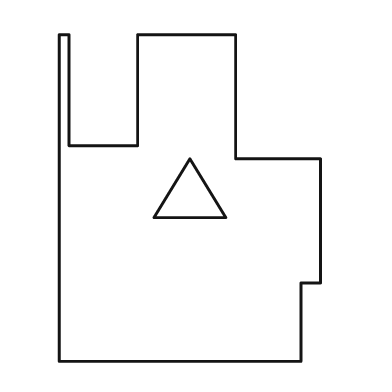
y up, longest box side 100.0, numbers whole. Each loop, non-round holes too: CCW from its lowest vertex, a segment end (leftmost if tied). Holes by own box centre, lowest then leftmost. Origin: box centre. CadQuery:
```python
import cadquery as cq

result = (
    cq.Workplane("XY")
    .moveTo(-40.0, -50.0)
    .lineTo(34.0, -50.0)
    .lineTo(34.0, -26.0)
    .lineTo(40.0, -26.0)
    .lineTo(40.0, 12.0)
    .lineTo(14.0, 12.0)
    .lineTo(14.0, 50.0)
    .lineTo(-16.0, 50.0)
    .lineTo(-16.0, 16.0)
    .lineTo(-37.0, 16.0)
    .lineTo(-37.0, 50.0)
    .lineTo(-40.0, 50.0)
    .close()
    .moveTo(-11.0, -6.0)
    .lineTo(11.0, -6.0)
    .lineTo(0.0, 12.0)
    .close()
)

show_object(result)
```